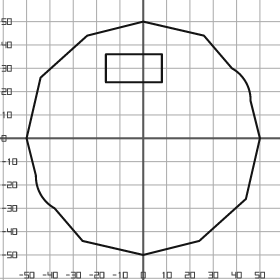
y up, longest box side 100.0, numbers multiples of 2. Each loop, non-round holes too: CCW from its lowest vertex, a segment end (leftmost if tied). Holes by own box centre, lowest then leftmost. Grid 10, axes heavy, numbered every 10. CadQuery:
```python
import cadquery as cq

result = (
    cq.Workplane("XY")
    .moveTo(0.0, -50.0)
    .lineTo(24.0, -44.0)
    .lineTo(44.0, -26.0)
    .lineTo(50.0, 0.0)
    .lineTo(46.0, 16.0)
    .threePointArc((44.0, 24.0), (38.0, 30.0))
    .lineTo(26.0, 44.0)
    .lineTo(0.0, 50.0)
    .lineTo(-24.0, 44.0)
    .lineTo(-44.0, 26.0)
    .lineTo(-50.0, 0.0)
    .lineTo(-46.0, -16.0)
    .threePointArc((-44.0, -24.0), (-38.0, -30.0))
    .lineTo(-26.0, -44.0)
    .close()
    .moveTo(-16.0, 24.0)
    .lineTo(8.0, 24.0)
    .lineTo(8.0, 36.0)
    .lineTo(-16.0, 36.0)
    .close()
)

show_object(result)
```